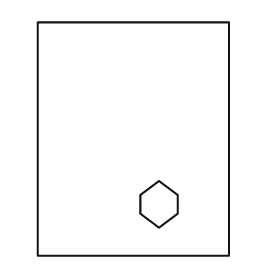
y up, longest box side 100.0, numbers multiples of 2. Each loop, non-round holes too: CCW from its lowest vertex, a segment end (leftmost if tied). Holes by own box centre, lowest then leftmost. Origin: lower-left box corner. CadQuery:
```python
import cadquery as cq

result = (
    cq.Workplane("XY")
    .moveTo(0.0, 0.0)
    .lineTo(82.0, 0.0)
    .lineTo(82.0, 100.0)
    .lineTo(0.0, 100.0)
    .close()
    .moveTo(52.0, 12.0)
    .lineTo(60.0, 18.0)
    .lineTo(60.0, 26.0)
    .lineTo(52.0, 32.0)
    .lineTo(44.0, 26.0)
    .lineTo(44.0, 18.0)
    .close()
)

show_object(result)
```